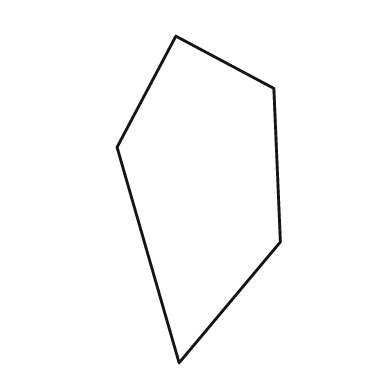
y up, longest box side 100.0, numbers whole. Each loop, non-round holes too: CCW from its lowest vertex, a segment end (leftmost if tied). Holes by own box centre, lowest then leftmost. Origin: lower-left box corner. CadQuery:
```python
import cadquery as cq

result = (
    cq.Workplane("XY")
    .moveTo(19.0, 0.0)
    .lineTo(50.0, 37.0)
    .lineTo(48.0, 84.0)
    .lineTo(18.0, 100.0)
    .lineTo(0.0, 66.0)
    .close()
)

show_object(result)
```